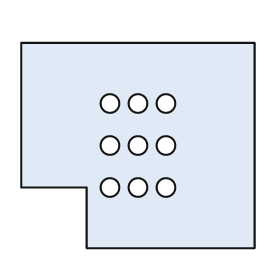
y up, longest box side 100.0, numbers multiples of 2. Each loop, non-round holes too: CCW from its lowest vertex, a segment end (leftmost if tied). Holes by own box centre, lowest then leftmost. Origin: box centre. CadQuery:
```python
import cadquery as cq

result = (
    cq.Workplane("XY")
    .moveTo(-22.0, -44.0)
    .lineTo(50.0, -44.0)
    .lineTo(50.0, 44.0)
    .lineTo(-50.0, 44.0)
    .lineTo(-50.0, -18.0)
    .lineTo(-22.0, -18.0)
    .close()
    .moveTo(-12.0, -18.0)
    .circle(4.0)
    .moveTo(0.0, -18.0)
    .circle(4.0)
    .moveTo(12.0, -18.0)
    .circle(4.0)
    .moveTo(-12.0, 0.0)
    .circle(4.0)
    .moveTo(0.0, 0.0)
    .circle(4.0)
    .moveTo(12.0, 0.0)
    .circle(4.0)
    .moveTo(-12.0, 18.0)
    .circle(4.0)
    .moveTo(0.0, 18.0)
    .circle(4.0)
    .moveTo(12.0, 18.0)
    .circle(4.0)
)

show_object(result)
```